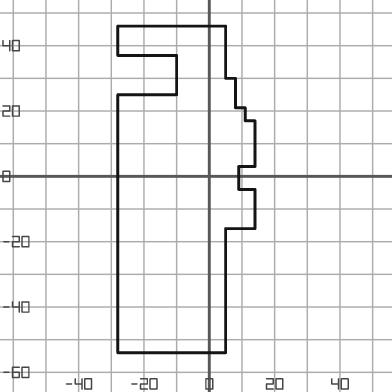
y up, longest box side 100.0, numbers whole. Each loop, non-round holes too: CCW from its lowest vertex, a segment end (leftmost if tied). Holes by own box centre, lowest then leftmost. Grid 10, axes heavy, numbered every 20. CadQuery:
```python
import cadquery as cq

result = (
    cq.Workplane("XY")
    .moveTo(-28.0, -54.0)
    .lineTo(5.0, -54.0)
    .lineTo(5.0, -16.0)
    .lineTo(14.0, -16.0)
    .lineTo(14.0, -4.0)
    .lineTo(9.0, -4.0)
    .lineTo(9.0, 3.0)
    .lineTo(14.0, 3.0)
    .lineTo(14.0, 17.0)
    .lineTo(11.0, 17.0)
    .lineTo(11.0, 21.0)
    .lineTo(8.0, 21.0)
    .lineTo(8.0, 30.0)
    .lineTo(5.0, 30.0)
    .lineTo(5.0, 46.0)
    .lineTo(-28.0, 46.0)
    .lineTo(-28.0, 37.0)
    .lineTo(-10.0, 37.0)
    .lineTo(-10.0, 25.0)
    .lineTo(-28.0, 25.0)
    .close()
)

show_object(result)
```